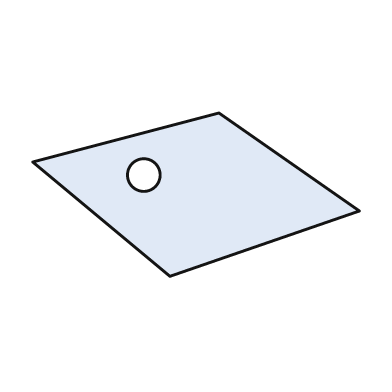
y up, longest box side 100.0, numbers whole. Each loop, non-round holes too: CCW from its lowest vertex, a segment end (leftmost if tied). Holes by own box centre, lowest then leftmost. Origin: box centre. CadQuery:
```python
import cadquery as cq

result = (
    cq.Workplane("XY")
    .moveTo(-8.0, -25.0)
    .lineTo(50.0, -5.0)
    .lineTo(7.0, 25.0)
    .lineTo(-50.0, 10.0)
    .close()
    .moveTo(-16.0, 6.0)
    .circle(5.0)
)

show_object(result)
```